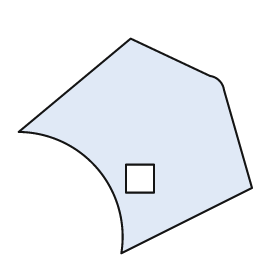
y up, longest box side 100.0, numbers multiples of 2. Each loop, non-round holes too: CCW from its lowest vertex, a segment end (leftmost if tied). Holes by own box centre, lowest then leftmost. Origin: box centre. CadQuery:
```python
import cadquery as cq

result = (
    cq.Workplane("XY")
    .moveTo(-6.0, -46.0)
    .lineTo(50.0, -18.0)
    .lineTo(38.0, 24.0)
    .threePointArc((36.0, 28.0), (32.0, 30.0))
    .lineTo(-2.0, 46.0)
    .lineTo(-50.0, 6.0)
    .threePointArc((-16.0, -10.0), (-6.0, -46.0))
    .close()
    .moveTo(-4.0, -20.0)
    .lineTo(8.0, -20.0)
    .lineTo(8.0, -8.0)
    .lineTo(-4.0, -8.0)
    .close()
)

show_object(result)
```